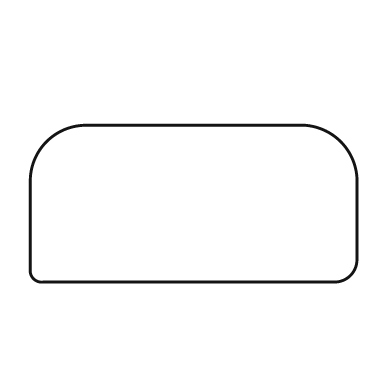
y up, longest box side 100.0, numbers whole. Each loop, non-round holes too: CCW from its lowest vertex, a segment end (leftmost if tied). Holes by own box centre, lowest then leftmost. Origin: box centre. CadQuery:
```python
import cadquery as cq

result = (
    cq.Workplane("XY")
    .moveTo(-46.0, -24.0)
    .lineTo(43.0, -24.0)
    .threePointArc((48.0, -22.0), (50.0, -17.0))
    .lineTo(50.0, 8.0)
    .threePointArc((45.0, 19.0), (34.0, 24.0))
    .lineTo(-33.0, 24.0)
    .threePointArc((-45.0, 19.0), (-50.0, 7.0))
    .lineTo(-50.0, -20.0)
    .threePointArc((-49.0, -23.0), (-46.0, -24.0))
    .close()
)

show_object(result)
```